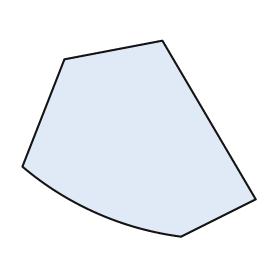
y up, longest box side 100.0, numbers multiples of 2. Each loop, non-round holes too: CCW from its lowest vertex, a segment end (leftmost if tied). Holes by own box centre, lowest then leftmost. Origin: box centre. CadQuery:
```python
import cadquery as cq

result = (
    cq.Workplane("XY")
    .moveTo(18.0, -42.0)
    .lineTo(50.0, -26.0)
    .lineTo(10.0, 42.0)
    .lineTo(-32.0, 34.0)
    .lineTo(-50.0, -12.0)
    .threePointArc((-18.0, -32.0), (18.0, -42.0))
    .close()
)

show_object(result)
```